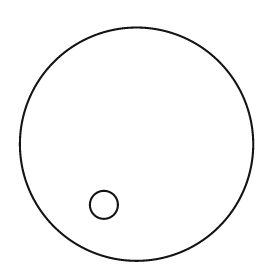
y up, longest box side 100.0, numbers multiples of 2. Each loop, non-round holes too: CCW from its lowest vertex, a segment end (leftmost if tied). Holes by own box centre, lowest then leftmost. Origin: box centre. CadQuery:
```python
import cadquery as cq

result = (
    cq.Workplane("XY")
    .moveTo(0.0, 0.0)
    .circle(50.0)
    .moveTo(-14.0, -26.0)
    .circle(6.0)
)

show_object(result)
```